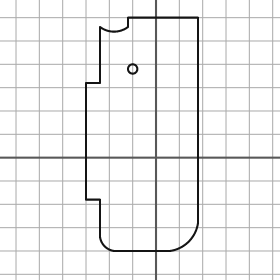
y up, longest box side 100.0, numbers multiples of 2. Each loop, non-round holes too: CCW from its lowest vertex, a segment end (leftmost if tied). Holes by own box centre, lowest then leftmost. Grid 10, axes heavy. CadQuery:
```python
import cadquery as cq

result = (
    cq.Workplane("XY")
    .moveTo(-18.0, -40.0)
    .lineTo(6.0, -40.0)
    .threePointArc((14.0, -36.0), (18.0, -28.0))
    .lineTo(18.0, 60.0)
    .lineTo(-12.0, 60.0)
    .lineTo(-12.0, 56.0)
    .threePointArc((-18.0, 54.0), (-24.0, 56.0))
    .lineTo(-24.0, 32.0)
    .lineTo(-30.0, 32.0)
    .lineTo(-30.0, -18.0)
    .lineTo(-24.0, -18.0)
    .lineTo(-24.0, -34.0)
    .threePointArc((-22.0, -38.0), (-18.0, -40.0))
    .close()
    .moveTo(-10.0, 38.0)
    .circle(2.0)
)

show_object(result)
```